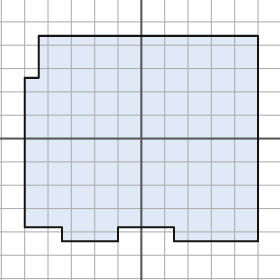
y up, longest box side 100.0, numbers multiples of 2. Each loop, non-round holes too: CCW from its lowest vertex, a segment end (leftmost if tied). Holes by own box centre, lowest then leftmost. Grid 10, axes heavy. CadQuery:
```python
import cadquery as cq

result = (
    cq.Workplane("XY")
    .moveTo(-34.0, -44.0)
    .lineTo(-10.0, -44.0)
    .lineTo(-10.0, -38.0)
    .lineTo(14.0, -38.0)
    .lineTo(14.0, -44.0)
    .lineTo(50.0, -44.0)
    .lineTo(50.0, 44.0)
    .lineTo(-44.0, 44.0)
    .lineTo(-44.0, 26.0)
    .lineTo(-50.0, 26.0)
    .lineTo(-50.0, -38.0)
    .lineTo(-34.0, -38.0)
    .close()
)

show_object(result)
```